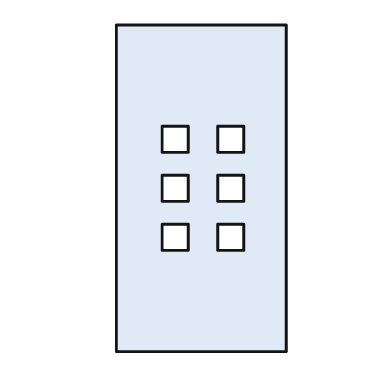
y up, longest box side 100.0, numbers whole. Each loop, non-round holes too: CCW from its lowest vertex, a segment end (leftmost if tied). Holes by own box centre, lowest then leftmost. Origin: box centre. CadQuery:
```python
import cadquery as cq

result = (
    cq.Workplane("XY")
    .moveTo(-26.0, -50.0)
    .lineTo(26.0, -50.0)
    .lineTo(26.0, 50.0)
    .lineTo(-26.0, 50.0)
    .close()
    .moveTo(-12.0, -19.0)
    .lineTo(-4.0, -19.0)
    .lineTo(-4.0, -11.0)
    .lineTo(-12.0, -11.0)
    .close()
    .moveTo(5.0, -19.0)
    .lineTo(13.0, -19.0)
    .lineTo(13.0, -11.0)
    .lineTo(5.0, -11.0)
    .close()
    .moveTo(-12.0, -4.0)
    .lineTo(-4.0, -4.0)
    .lineTo(-4.0, 4.0)
    .lineTo(-12.0, 4.0)
    .close()
    .moveTo(5.0, -4.0)
    .lineTo(13.0, -4.0)
    .lineTo(13.0, 4.0)
    .lineTo(5.0, 4.0)
    .close()
    .moveTo(-12.0, 11.0)
    .lineTo(-4.0, 11.0)
    .lineTo(-4.0, 19.0)
    .lineTo(-12.0, 19.0)
    .close()
    .moveTo(5.0, 11.0)
    .lineTo(13.0, 11.0)
    .lineTo(13.0, 19.0)
    .lineTo(5.0, 19.0)
    .close()
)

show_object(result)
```